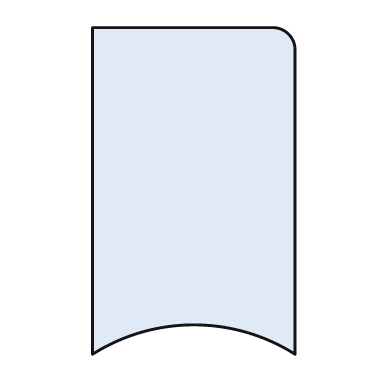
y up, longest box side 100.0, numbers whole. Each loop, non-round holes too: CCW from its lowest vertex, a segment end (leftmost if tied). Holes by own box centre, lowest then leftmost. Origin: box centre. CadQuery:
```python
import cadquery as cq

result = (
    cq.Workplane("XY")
    .moveTo(-31.0, -50.0)
    .threePointArc((0.0, -41.0), (31.0, -50.0))
    .lineTo(31.0, 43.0)
    .threePointArc((29.0, 48.0), (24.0, 50.0))
    .lineTo(-31.0, 50.0)
    .close()
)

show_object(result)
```